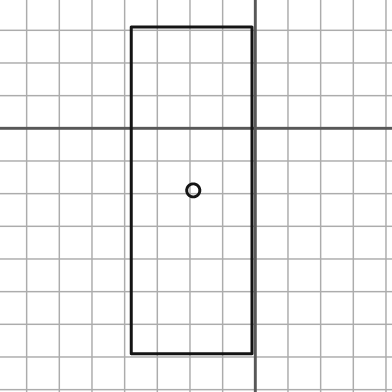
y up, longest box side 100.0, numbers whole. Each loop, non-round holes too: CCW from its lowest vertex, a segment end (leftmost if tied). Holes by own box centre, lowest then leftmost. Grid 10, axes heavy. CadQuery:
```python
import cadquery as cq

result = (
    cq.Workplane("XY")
    .moveTo(-38.0, -69.0)
    .lineTo(-1.0, -69.0)
    .lineTo(-1.0, 31.0)
    .lineTo(-38.0, 31.0)
    .close()
    .moveTo(-19.0, -19.0)
    .circle(2.0)
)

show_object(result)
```